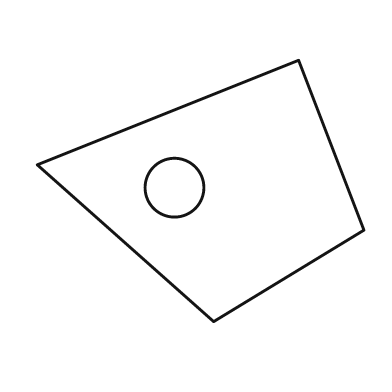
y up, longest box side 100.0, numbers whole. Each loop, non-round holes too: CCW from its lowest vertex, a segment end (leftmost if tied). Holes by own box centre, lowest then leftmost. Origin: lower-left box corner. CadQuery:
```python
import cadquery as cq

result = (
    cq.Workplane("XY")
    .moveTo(54.0, 0.0)
    .lineTo(100.0, 28.0)
    .lineTo(80.0, 80.0)
    .lineTo(0.0, 48.0)
    .close()
    .moveTo(42.0, 41.0)
    .circle(9.0)
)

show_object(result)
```